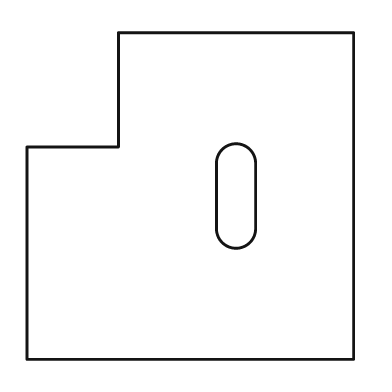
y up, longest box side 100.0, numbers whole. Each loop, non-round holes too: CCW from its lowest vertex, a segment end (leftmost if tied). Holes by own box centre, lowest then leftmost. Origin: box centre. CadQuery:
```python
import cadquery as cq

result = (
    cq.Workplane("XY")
    .moveTo(-50.0, -50.0)
    .lineTo(50.0, -50.0)
    .lineTo(50.0, 50.0)
    .lineTo(-22.0, 50.0)
    .lineTo(-22.0, 15.0)
    .lineTo(-50.0, 15.0)
    .close()
    .moveTo(8.0, -10.0)
    .threePointArc((14.0, -16.0), (20.0, -10.0))
    .lineTo(20.0, 10.0)
    .threePointArc((14.0, 16.0), (8.0, 10.0))
    .close()
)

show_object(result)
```